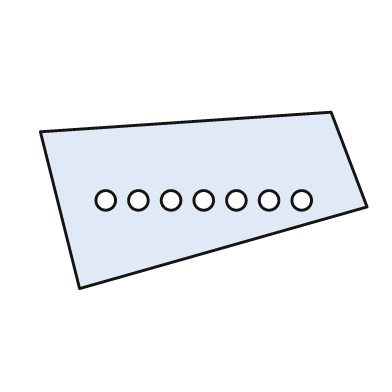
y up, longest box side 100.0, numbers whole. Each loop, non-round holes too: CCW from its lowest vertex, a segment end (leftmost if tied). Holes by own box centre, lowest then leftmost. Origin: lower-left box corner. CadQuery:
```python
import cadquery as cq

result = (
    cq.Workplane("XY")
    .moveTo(12.0, 0.0)
    .lineTo(100.0, 25.0)
    .lineTo(89.0, 54.0)
    .lineTo(0.0, 48.0)
    .close()
    .moveTo(20.0, 27.0)
    .circle(3.0)
    .moveTo(30.0, 27.0)
    .circle(3.0)
    .moveTo(40.0, 27.0)
    .circle(3.0)
    .moveTo(50.0, 27.0)
    .circle(3.0)
    .moveTo(60.0, 27.0)
    .circle(3.0)
    .moveTo(70.0, 27.0)
    .circle(3.0)
    .moveTo(80.0, 27.0)
    .circle(3.0)
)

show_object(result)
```